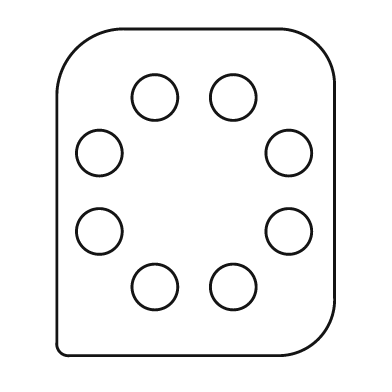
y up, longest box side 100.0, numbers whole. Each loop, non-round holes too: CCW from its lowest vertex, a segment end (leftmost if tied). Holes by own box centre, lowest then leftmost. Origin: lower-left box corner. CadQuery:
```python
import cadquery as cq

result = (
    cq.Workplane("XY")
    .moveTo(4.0, 0.0)
    .lineTo(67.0, 0.0)
    .threePointArc((80.0, 5.0), (85.0, 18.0))
    .lineTo(85.0, 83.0)
    .threePointArc((80.0, 95.0), (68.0, 100.0))
    .lineTo(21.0, 100.0)
    .threePointArc((6.0, 94.0), (0.0, 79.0))
    .lineTo(0.0, 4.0)
    .threePointArc((1.0, 1.0), (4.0, 0.0))
    .close()
    .moveTo(30.0, 21.0)
    .circle(7.0)
    .moveTo(54.0, 21.0)
    .circle(7.0)
    .moveTo(13.0, 38.0)
    .circle(7.0)
    .moveTo(71.0, 38.0)
    .circle(7.0)
    .moveTo(13.0, 62.0)
    .circle(7.0)
    .moveTo(71.0, 62.0)
    .circle(7.0)
    .moveTo(30.0, 79.0)
    .circle(7.0)
    .moveTo(54.0, 79.0)
    .circle(7.0)
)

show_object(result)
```